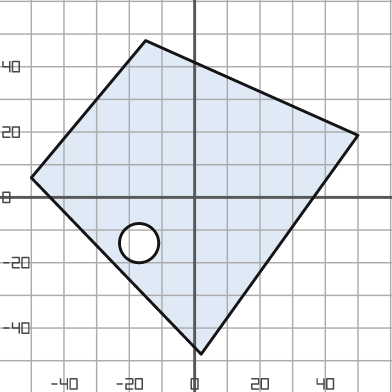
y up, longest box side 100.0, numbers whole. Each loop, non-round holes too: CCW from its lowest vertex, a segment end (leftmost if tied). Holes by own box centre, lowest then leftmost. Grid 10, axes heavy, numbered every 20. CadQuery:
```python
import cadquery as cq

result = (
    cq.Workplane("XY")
    .moveTo(2.0, -48.0)
    .lineTo(50.0, 19.0)
    .lineTo(-15.0, 48.0)
    .lineTo(-50.0, 6.0)
    .close()
    .moveTo(-17.0, -14.0)
    .circle(6.0)
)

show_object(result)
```